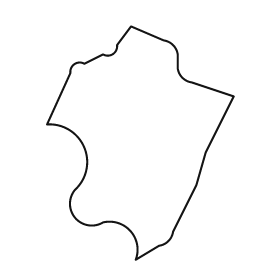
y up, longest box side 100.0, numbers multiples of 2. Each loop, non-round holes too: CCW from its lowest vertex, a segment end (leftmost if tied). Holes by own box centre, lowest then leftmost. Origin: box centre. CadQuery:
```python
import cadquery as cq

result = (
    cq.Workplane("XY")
    .moveTo(-2.0, -50.0)
    .lineTo(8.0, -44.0)
    .threePointArc((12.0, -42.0), (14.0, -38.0))
    .lineTo(24.0, -18.0)
    .lineTo(28.0, -4.0)
    .lineTo(40.0, 20.0)
    .lineTo(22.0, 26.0)
    .threePointArc((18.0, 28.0), (16.0, 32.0))
    .lineTo(16.0, 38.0)
    .threePointArc((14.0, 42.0), (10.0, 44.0))
    .lineTo(-4.0, 50.0)
    .lineTo(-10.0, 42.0)
    .threePointArc((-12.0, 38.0), (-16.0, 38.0))
    .lineTo(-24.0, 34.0)
    .threePointArc((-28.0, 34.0), (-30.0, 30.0))
    .lineTo(-40.0, 8.0)
    .threePointArc((-24.0, -2.0), (-28.0, -20.0))
    .threePointArc((-28.0, -32.0), (-16.0, -34.0))
    .threePointArc((-4.0, -38.0), (-2.0, -50.0))
    .close()
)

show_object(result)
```